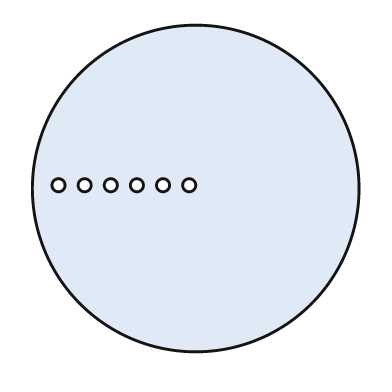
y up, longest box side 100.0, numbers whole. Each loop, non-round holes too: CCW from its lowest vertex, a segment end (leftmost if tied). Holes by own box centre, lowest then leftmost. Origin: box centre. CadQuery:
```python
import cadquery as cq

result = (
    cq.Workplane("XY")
    .moveTo(0.0, 0.0)
    .circle(50.0)
    .moveTo(-42.0, 1.0)
    .circle(2.0)
    .moveTo(-34.0, 1.0)
    .circle(2.0)
    .moveTo(-26.0, 1.0)
    .circle(2.0)
    .moveTo(-18.0, 1.0)
    .circle(2.0)
    .moveTo(-10.0, 1.0)
    .circle(2.0)
    .moveTo(-2.0, 1.0)
    .circle(2.0)
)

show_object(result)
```